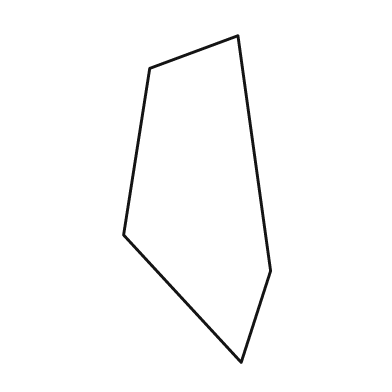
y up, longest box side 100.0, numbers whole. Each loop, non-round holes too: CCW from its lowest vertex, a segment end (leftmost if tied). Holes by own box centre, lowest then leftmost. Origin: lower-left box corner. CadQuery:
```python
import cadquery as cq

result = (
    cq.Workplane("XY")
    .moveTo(36.0, 0.0)
    .lineTo(45.0, 28.0)
    .lineTo(35.0, 100.0)
    .lineTo(8.0, 90.0)
    .lineTo(0.0, 39.0)
    .close()
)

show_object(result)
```